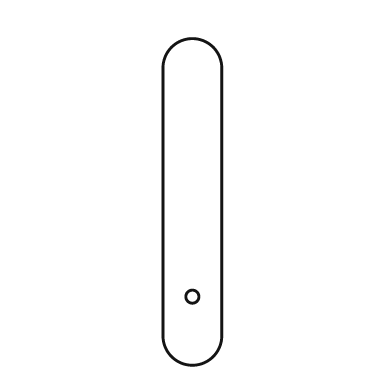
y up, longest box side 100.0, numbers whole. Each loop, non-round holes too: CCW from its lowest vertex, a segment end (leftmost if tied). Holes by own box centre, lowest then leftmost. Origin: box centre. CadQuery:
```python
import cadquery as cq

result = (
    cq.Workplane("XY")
    .moveTo(-9.0, -41.0)
    .threePointArc((0.0, -50.0), (9.0, -41.0))
    .lineTo(9.0, 41.0)
    .threePointArc((0.0, 50.0), (-9.0, 41.0))
    .close()
    .moveTo(0.0, -29.0)
    .circle(2.0)
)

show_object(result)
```